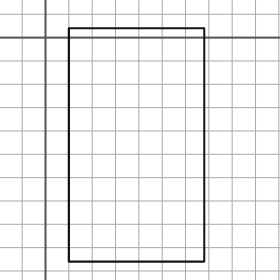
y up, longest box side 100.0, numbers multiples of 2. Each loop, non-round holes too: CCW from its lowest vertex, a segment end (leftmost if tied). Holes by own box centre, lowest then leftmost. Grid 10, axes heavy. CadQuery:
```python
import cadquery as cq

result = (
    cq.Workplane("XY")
    .moveTo(10.0, -96.0)
    .lineTo(68.0, -96.0)
    .lineTo(68.0, 4.0)
    .lineTo(10.0, 4.0)
    .close()
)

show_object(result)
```